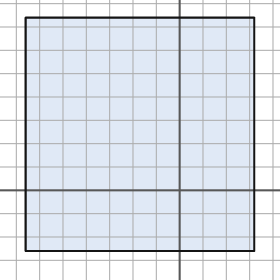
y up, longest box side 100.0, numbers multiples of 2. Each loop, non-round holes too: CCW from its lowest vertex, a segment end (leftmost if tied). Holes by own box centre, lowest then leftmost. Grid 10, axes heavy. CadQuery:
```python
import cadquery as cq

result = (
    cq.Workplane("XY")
    .moveTo(-66.0, -26.0)
    .lineTo(32.0, -26.0)
    .lineTo(32.0, 74.0)
    .lineTo(-66.0, 74.0)
    .close()
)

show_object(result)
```